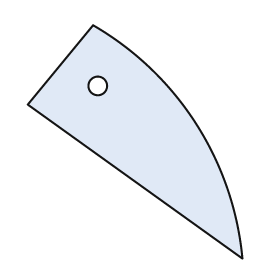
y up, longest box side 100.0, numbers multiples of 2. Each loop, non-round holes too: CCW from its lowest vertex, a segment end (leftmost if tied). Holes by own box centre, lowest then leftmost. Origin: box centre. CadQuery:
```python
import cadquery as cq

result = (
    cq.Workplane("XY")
    .moveTo(46.0, -50.0)
    .threePointArc((26.0, 8.0), (-18.0, 50.0))
    .lineTo(-46.0, 16.0)
    .close()
    .moveTo(-16.0, 24.0)
    .circle(4.0)
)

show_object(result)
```